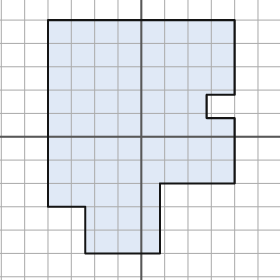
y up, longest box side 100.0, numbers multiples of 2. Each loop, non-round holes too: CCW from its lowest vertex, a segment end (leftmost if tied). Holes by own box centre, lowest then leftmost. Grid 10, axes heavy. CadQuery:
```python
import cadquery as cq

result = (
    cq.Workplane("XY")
    .moveTo(-24.0, -50.0)
    .lineTo(8.0, -50.0)
    .lineTo(8.0, -20.0)
    .lineTo(40.0, -20.0)
    .lineTo(40.0, 8.0)
    .lineTo(28.0, 8.0)
    .lineTo(28.0, 18.0)
    .lineTo(40.0, 18.0)
    .lineTo(40.0, 50.0)
    .lineTo(-40.0, 50.0)
    .lineTo(-40.0, -30.0)
    .lineTo(-24.0, -30.0)
    .close()
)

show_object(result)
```